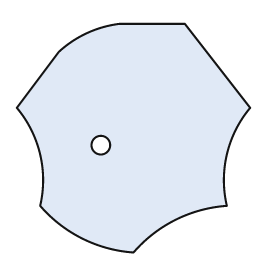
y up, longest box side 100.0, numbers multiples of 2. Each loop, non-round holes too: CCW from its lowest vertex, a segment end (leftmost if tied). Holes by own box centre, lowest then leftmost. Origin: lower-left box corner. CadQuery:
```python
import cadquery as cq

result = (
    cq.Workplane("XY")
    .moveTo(50.0, 0.0)
    .threePointArc((68.0, 14.0), (90.0, 20.0))
    .threePointArc((90.0, 42.0), (100.0, 62.0))
    .lineTo(72.0, 98.0)
    .lineTo(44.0, 98.0)
    .threePointArc((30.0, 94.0), (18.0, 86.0))
    .lineTo(0.0, 62.0)
    .threePointArc((10.0, 42.0), (10.0, 20.0))
    .threePointArc((28.0, 6.0), (50.0, 0.0))
    .close()
    .moveTo(36.0, 46.0)
    .circle(4.0)
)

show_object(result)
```